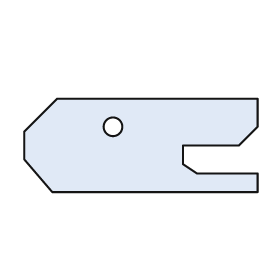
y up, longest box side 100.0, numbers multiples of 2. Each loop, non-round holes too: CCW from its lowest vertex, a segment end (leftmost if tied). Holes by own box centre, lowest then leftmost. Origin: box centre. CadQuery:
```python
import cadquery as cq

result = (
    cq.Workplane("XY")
    .moveTo(-38.0, -20.0)
    .lineTo(50.0, -20.0)
    .lineTo(50.0, -12.0)
    .lineTo(24.0, -12.0)
    .lineTo(18.0, -8.0)
    .lineTo(18.0, 0.0)
    .lineTo(42.0, 0.0)
    .lineTo(50.0, 8.0)
    .lineTo(50.0, 20.0)
    .lineTo(-36.0, 20.0)
    .lineTo(-50.0, 6.0)
    .lineTo(-50.0, -6.0)
    .close()
    .moveTo(-12.0, 8.0)
    .circle(4.0)
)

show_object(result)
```